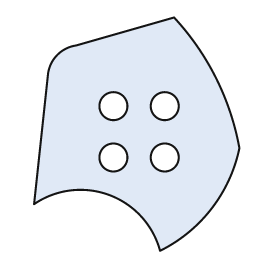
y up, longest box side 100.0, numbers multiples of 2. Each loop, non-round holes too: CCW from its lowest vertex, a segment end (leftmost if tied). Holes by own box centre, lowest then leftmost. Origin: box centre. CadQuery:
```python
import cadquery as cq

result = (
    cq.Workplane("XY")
    .moveTo(10.0, -50.0)
    .threePointArc((32.0, -32.0), (44.0, -6.0))
    .threePointArc((34.0, 24.0), (16.0, 50.0))
    .lineTo(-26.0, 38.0)
    .threePointArc((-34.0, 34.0), (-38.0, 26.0))
    .lineTo(-44.0, -30.0)
    .threePointArc((-12.0, -26.0), (10.0, -50.0))
    .close()
    .moveTo(-10.0, -10.0)
    .circle(6.0)
    .moveTo(12.0, -10.0)
    .circle(6.0)
    .moveTo(-10.0, 12.0)
    .circle(6.0)
    .moveTo(12.0, 12.0)
    .circle(6.0)
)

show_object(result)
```